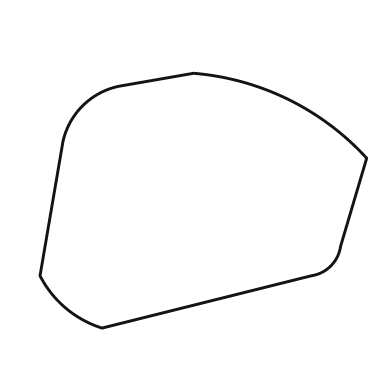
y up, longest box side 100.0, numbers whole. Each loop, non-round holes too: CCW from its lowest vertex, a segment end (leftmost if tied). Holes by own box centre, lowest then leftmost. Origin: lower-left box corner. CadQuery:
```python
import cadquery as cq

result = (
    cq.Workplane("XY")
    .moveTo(19.0, 0.0)
    .lineTo(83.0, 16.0)
    .threePointArc((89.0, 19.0), (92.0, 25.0))
    .lineTo(100.0, 52.0)
    .threePointArc((76.0, 70.0), (47.0, 78.0))
    .lineTo(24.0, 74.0)
    .threePointArc((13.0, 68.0), (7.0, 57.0))
    .lineTo(0.0, 16.0)
    .threePointArc((8.0, 6.0), (19.0, 0.0))
    .close()
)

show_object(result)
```